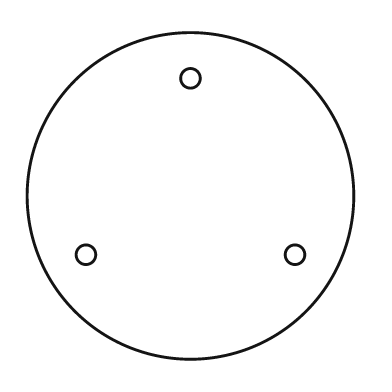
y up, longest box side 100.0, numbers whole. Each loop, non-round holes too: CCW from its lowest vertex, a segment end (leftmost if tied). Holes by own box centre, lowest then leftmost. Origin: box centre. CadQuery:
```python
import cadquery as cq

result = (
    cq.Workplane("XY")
    .moveTo(0.0, 0.0)
    .circle(50.0)
    .moveTo(-32.0, -18.0)
    .circle(3.0)
    .moveTo(32.0, -18.0)
    .circle(3.0)
    .moveTo(0.0, 36.0)
    .circle(3.0)
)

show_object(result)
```